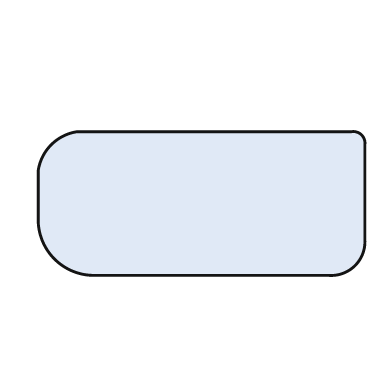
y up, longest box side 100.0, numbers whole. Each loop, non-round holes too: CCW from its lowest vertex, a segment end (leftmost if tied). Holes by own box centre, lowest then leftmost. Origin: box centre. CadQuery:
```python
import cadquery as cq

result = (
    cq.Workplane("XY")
    .moveTo(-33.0, -22.0)
    .lineTo(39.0, -22.0)
    .threePointArc((47.0, -19.0), (50.0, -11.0))
    .lineTo(50.0, 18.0)
    .threePointArc((49.0, 21.0), (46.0, 22.0))
    .lineTo(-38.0, 22.0)
    .threePointArc((-46.0, 18.0), (-50.0, 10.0))
    .lineTo(-50.0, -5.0)
    .threePointArc((-45.0, -17.0), (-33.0, -22.0))
    .close()
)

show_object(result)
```